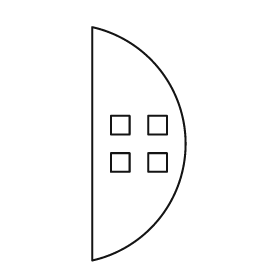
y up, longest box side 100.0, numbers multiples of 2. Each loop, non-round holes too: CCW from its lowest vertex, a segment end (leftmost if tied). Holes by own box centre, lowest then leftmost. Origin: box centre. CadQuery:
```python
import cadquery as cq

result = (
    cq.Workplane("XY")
    .moveTo(-20.0, -50.0)
    .threePointArc((20.0, 0.0), (-20.0, 50.0))
    .close()
    .moveTo(-12.0, -12.0)
    .lineTo(-4.0, -12.0)
    .lineTo(-4.0, -4.0)
    .lineTo(-12.0, -4.0)
    .close()
    .moveTo(4.0, -12.0)
    .lineTo(12.0, -12.0)
    .lineTo(12.0, -4.0)
    .lineTo(4.0, -4.0)
    .close()
    .moveTo(-12.0, 4.0)
    .lineTo(-4.0, 4.0)
    .lineTo(-4.0, 12.0)
    .lineTo(-12.0, 12.0)
    .close()
    .moveTo(4.0, 4.0)
    .lineTo(12.0, 4.0)
    .lineTo(12.0, 12.0)
    .lineTo(4.0, 12.0)
    .close()
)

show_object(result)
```